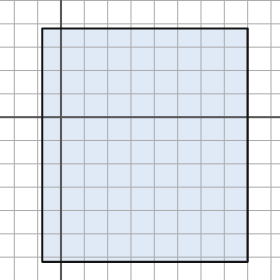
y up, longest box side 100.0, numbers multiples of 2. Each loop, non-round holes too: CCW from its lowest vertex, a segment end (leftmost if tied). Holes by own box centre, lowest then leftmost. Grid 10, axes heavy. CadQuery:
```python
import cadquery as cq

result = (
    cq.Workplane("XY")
    .moveTo(-8.0, -62.0)
    .lineTo(80.0, -62.0)
    .lineTo(80.0, 38.0)
    .lineTo(-8.0, 38.0)
    .close()
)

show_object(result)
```